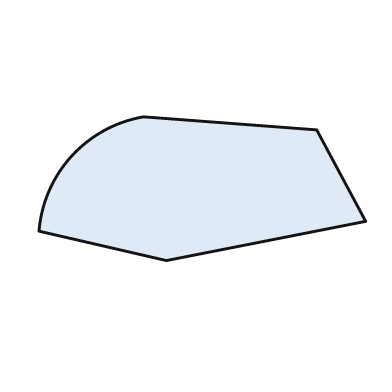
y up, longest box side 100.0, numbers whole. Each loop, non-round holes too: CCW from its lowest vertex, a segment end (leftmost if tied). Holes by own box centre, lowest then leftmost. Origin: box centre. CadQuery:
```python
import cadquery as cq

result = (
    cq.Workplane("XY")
    .moveTo(-11.0, -22.0)
    .lineTo(50.0, -10.0)
    .lineTo(35.0, 18.0)
    .lineTo(-18.0, 22.0)
    .threePointArc((-40.0, 10.0), (-50.0, -13.0))
    .close()
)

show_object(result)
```